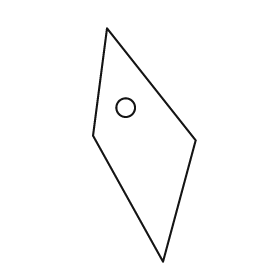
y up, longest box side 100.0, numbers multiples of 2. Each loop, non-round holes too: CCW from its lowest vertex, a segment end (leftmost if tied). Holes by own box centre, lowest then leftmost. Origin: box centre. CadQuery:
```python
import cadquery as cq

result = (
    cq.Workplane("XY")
    .moveTo(8.0, -50.0)
    .lineTo(22.0, 2.0)
    .lineTo(-16.0, 50.0)
    .lineTo(-22.0, 4.0)
    .close()
    .moveTo(-8.0, 16.0)
    .circle(4.0)
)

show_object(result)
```